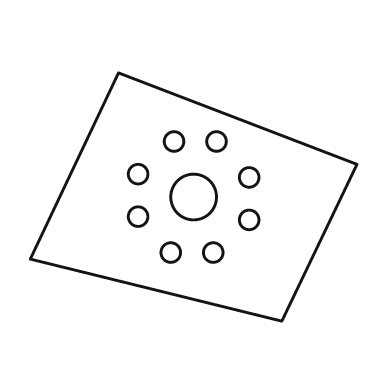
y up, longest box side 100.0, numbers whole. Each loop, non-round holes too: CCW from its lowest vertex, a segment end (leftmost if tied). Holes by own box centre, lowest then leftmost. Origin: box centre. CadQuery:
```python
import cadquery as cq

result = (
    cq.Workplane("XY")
    .moveTo(27.0, -38.0)
    .lineTo(50.0, 10.0)
    .lineTo(-23.0, 38.0)
    .lineTo(-50.0, -19.0)
    .close()
    .moveTo(-7.0, -17.0)
    .circle(3.0)
    .moveTo(6.0, -17.0)
    .circle(3.0)
    .moveTo(17.0, -7.0)
    .circle(3.0)
    .moveTo(-17.0, -6.0)
    .circle(3.0)
    .moveTo(0.0, 0.0)
    .circle(7.0)
    .moveTo(17.0, 6.0)
    .circle(3.0)
    .moveTo(-17.0, 7.0)
    .circle(3.0)
    .moveTo(-6.0, 17.0)
    .circle(3.0)
    .moveTo(7.0, 17.0)
    .circle(3.0)
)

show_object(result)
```